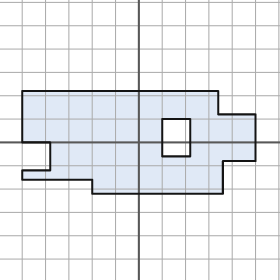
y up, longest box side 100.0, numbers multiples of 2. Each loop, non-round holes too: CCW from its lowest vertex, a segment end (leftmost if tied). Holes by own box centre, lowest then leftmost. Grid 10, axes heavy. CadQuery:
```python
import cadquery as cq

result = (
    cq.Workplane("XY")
    .moveTo(-20.0, -22.0)
    .lineTo(36.0, -22.0)
    .lineTo(36.0, -8.0)
    .lineTo(50.0, -8.0)
    .lineTo(50.0, 12.0)
    .lineTo(34.0, 12.0)
    .lineTo(34.0, 22.0)
    .lineTo(-50.0, 22.0)
    .lineTo(-50.0, 0.0)
    .lineTo(-38.0, 0.0)
    .lineTo(-38.0, -12.0)
    .lineTo(-50.0, -12.0)
    .lineTo(-50.0, -16.0)
    .lineTo(-20.0, -16.0)
    .close()
    .moveTo(10.0, -6.0)
    .lineTo(22.0, -6.0)
    .lineTo(22.0, 10.0)
    .lineTo(10.0, 10.0)
    .close()
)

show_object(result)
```